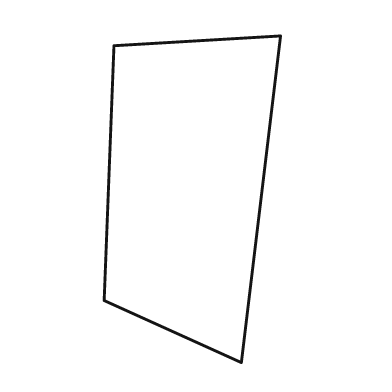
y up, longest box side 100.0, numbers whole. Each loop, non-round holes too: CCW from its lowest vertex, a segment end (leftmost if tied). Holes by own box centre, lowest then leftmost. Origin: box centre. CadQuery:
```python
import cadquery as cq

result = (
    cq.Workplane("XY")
    .moveTo(15.0, -50.0)
    .lineTo(27.0, 50.0)
    .lineTo(-24.0, 47.0)
    .lineTo(-27.0, -31.0)
    .close()
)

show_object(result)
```